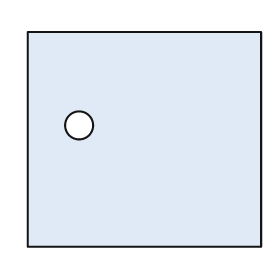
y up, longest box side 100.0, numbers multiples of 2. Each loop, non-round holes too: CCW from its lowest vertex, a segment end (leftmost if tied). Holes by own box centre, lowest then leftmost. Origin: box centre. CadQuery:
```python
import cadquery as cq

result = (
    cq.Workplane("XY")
    .moveTo(-50.0, -46.0)
    .lineTo(50.0, -46.0)
    .lineTo(50.0, 46.0)
    .lineTo(-50.0, 46.0)
    .close()
    .moveTo(-28.0, 6.0)
    .circle(6.0)
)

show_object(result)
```